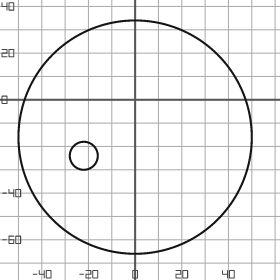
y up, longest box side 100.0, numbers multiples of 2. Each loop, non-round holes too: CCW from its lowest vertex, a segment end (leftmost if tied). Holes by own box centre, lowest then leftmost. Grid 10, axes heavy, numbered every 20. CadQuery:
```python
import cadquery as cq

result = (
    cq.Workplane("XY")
    .moveTo(0.0, -16.0)
    .circle(50.0)
    .moveTo(-22.0, -24.0)
    .circle(6.0)
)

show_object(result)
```